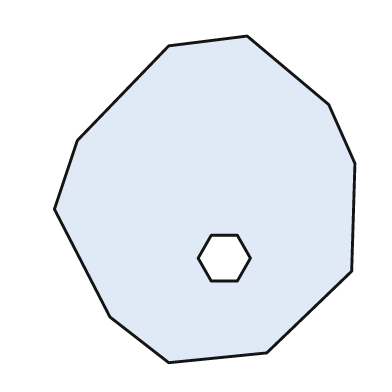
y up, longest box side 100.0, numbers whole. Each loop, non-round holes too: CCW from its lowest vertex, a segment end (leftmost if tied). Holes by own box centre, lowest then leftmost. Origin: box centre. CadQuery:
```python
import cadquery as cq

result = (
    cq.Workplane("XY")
    .moveTo(-11.0, -50.0)
    .lineTo(19.0, -47.0)
    .lineTo(45.0, -22.0)
    .lineTo(46.0, 11.0)
    .lineTo(38.0, 29.0)
    .lineTo(13.0, 50.0)
    .lineTo(-11.0, 47.0)
    .lineTo(-39.0, 18.0)
    .lineTo(-46.0, -3.0)
    .lineTo(-29.0, -36.0)
    .close()
    .moveTo(2.0, -25.0)
    .lineTo(10.0, -25.0)
    .lineTo(14.0, -18.0)
    .lineTo(10.0, -11.0)
    .lineTo(2.0, -11.0)
    .lineTo(-2.0, -18.0)
    .close()
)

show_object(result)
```